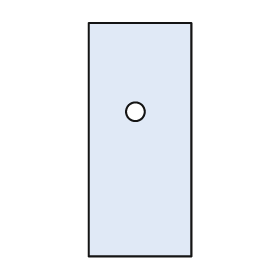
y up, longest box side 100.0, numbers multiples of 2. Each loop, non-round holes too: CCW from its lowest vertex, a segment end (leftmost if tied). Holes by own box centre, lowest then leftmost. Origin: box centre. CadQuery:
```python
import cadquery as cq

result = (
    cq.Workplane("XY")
    .moveTo(-22.0, -50.0)
    .lineTo(22.0, -50.0)
    .lineTo(22.0, 50.0)
    .lineTo(-22.0, 50.0)
    .close()
    .moveTo(-2.0, 12.0)
    .circle(4.0)
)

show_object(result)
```